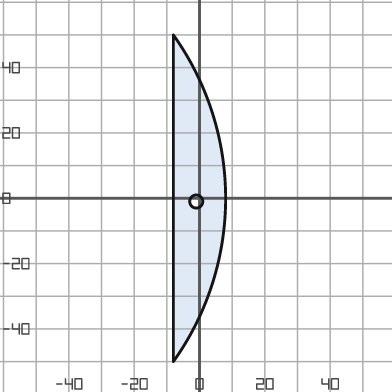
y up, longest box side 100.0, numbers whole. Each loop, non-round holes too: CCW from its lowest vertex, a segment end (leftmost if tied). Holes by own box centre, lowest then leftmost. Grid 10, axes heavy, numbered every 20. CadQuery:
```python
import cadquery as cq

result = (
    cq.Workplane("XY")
    .moveTo(-8.0, -50.0)
    .threePointArc((8.0, 0.0), (-8.0, 50.0))
    .close()
    .moveTo(-1.0, -1.0)
    .circle(2.0)
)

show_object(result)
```